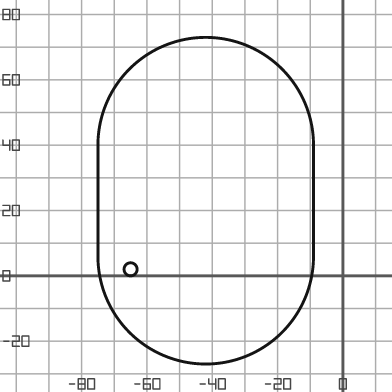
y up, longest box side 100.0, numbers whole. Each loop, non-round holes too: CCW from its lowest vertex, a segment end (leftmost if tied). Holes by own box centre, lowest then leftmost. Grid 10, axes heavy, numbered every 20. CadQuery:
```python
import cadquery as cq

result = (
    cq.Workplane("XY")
    .moveTo(-75.0, 6.0)
    .threePointArc((-42.0, -27.0), (-9.0, 6.0))
    .lineTo(-9.0, 40.0)
    .threePointArc((-42.0, 73.0), (-75.0, 40.0))
    .close()
    .moveTo(-65.0, 2.0)
    .circle(2.0)
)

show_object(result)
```